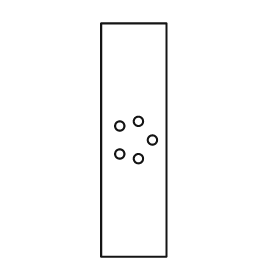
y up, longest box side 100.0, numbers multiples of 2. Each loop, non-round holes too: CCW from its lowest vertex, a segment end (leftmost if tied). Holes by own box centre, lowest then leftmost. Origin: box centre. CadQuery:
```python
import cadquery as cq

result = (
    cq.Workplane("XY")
    .moveTo(-14.0, -50.0)
    .lineTo(14.0, -50.0)
    .lineTo(14.0, 50.0)
    .lineTo(-14.0, 50.0)
    .close()
    .moveTo(2.0, -8.0)
    .circle(2.0)
    .moveTo(-6.0, -6.0)
    .circle(2.0)
    .moveTo(8.0, 0.0)
    .circle(2.0)
    .moveTo(-6.0, 6.0)
    .circle(2.0)
    .moveTo(2.0, 8.0)
    .circle(2.0)
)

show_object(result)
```